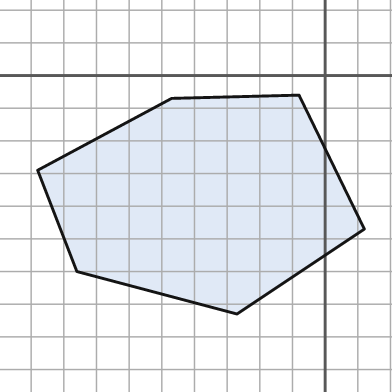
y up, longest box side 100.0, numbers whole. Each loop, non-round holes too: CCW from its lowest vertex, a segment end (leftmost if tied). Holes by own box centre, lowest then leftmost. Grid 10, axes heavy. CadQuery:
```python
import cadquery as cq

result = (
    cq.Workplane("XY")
    .moveTo(-27.0, -73.0)
    .lineTo(12.0, -47.0)
    .lineTo(-8.0, -6.0)
    .lineTo(-47.0, -7.0)
    .lineTo(-88.0, -29.0)
    .lineTo(-76.0, -60.0)
    .close()
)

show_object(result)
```